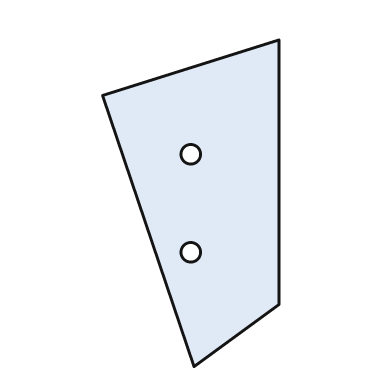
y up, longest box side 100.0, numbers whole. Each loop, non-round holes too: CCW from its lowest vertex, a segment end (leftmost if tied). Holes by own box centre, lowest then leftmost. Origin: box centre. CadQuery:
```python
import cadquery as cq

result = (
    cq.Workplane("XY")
    .moveTo(1.0, -50.0)
    .lineTo(27.0, -31.0)
    .lineTo(27.0, 50.0)
    .lineTo(-27.0, 33.0)
    .close()
    .moveTo(0.0, -15.0)
    .circle(3.0)
    .moveTo(0.0, 15.0)
    .circle(3.0)
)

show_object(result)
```